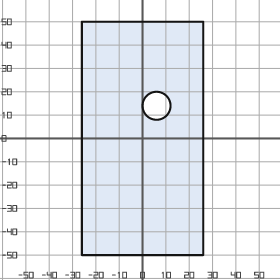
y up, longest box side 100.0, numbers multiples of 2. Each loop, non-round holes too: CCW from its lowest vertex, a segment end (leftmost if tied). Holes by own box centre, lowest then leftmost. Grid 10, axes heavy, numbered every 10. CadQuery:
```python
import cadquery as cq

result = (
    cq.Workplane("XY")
    .moveTo(-26.0, -50.0)
    .lineTo(26.0, -50.0)
    .lineTo(26.0, 50.0)
    .lineTo(-26.0, 50.0)
    .close()
    .moveTo(6.0, 14.0)
    .circle(6.0)
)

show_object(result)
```